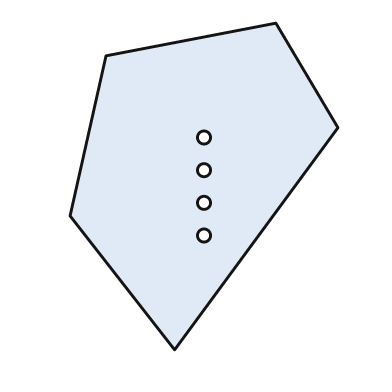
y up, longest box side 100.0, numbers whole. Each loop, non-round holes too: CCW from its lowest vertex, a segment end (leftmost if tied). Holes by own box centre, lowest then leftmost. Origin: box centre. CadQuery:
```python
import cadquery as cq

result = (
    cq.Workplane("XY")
    .moveTo(-9.0, -50.0)
    .lineTo(41.0, 18.0)
    .lineTo(22.0, 50.0)
    .lineTo(-30.0, 40.0)
    .lineTo(-41.0, -9.0)
    .close()
    .moveTo(0.0, -15.0)
    .circle(2.0)
    .moveTo(0.0, -5.0)
    .circle(2.0)
    .moveTo(0.0, 5.0)
    .circle(2.0)
    .moveTo(0.0, 15.0)
    .circle(2.0)
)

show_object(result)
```